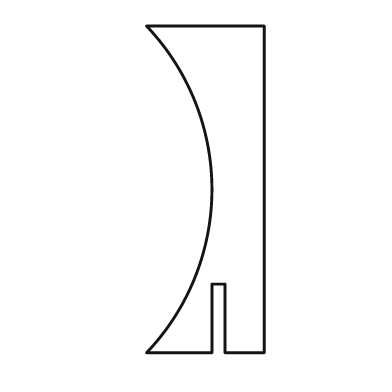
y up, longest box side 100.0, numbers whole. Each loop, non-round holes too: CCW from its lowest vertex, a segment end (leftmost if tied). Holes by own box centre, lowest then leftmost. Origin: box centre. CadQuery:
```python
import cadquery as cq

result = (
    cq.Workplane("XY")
    .moveTo(-18.0, -50.0)
    .lineTo(2.0, -50.0)
    .lineTo(2.0, -29.0)
    .lineTo(6.0, -29.0)
    .lineTo(6.0, -50.0)
    .lineTo(18.0, -50.0)
    .lineTo(18.0, 50.0)
    .lineTo(-18.0, 50.0)
    .threePointArc((2.0, 0.0), (-18.0, -50.0))
    .close()
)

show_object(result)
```